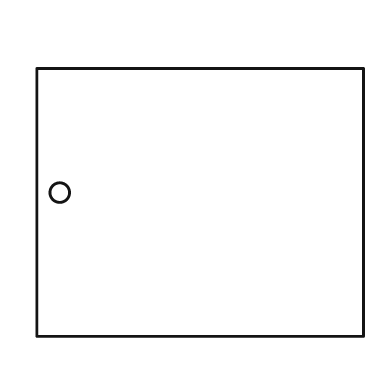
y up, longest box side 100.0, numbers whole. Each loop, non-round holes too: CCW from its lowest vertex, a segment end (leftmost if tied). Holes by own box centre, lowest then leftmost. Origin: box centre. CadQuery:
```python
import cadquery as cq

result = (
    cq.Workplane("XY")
    .moveTo(-50.0, -41.0)
    .lineTo(50.0, -41.0)
    .lineTo(50.0, 41.0)
    .lineTo(-50.0, 41.0)
    .close()
    .moveTo(-43.0, 3.0)
    .circle(3.0)
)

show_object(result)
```